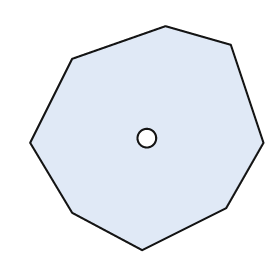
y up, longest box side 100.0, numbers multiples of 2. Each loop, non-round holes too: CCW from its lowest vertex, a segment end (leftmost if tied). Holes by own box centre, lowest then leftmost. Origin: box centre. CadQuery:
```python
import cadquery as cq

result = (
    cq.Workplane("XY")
    .moveTo(-2.0, -48.0)
    .lineTo(34.0, -30.0)
    .lineTo(50.0, -2.0)
    .lineTo(36.0, 40.0)
    .lineTo(8.0, 48.0)
    .lineTo(-32.0, 34.0)
    .lineTo(-50.0, -2.0)
    .lineTo(-32.0, -32.0)
    .close()
    .moveTo(0.0, 0.0)
    .circle(4.0)
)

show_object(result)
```